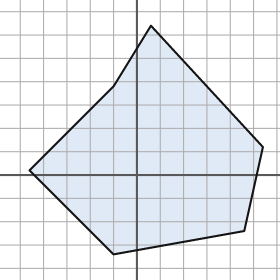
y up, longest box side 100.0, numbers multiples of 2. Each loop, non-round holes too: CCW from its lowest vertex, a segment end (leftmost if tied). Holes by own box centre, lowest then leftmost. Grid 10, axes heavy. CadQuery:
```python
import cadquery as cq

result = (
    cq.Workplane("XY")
    .moveTo(-10.0, -34.0)
    .lineTo(46.0, -24.0)
    .lineTo(54.0, 12.0)
    .lineTo(6.0, 64.0)
    .lineTo(-10.0, 38.0)
    .lineTo(-46.0, 2.0)
    .close()
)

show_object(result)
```